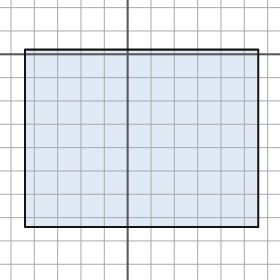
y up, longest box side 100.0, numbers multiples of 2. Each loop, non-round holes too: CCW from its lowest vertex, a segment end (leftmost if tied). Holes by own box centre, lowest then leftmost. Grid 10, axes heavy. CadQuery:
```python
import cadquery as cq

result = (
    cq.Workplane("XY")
    .moveTo(-44.0, -74.0)
    .lineTo(56.0, -74.0)
    .lineTo(56.0, 2.0)
    .lineTo(-44.0, 2.0)
    .close()
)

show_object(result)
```